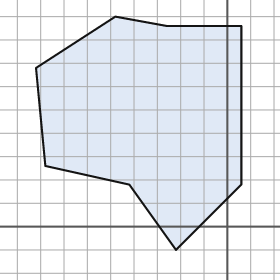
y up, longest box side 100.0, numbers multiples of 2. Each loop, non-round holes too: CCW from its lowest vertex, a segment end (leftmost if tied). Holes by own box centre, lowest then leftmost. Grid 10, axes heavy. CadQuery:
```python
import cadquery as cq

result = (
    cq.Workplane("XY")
    .moveTo(-22.0, -10.0)
    .lineTo(6.0, 18.0)
    .lineTo(6.0, 86.0)
    .lineTo(-26.0, 86.0)
    .lineTo(-48.0, 90.0)
    .lineTo(-82.0, 68.0)
    .lineTo(-78.0, 26.0)
    .lineTo(-42.0, 18.0)
    .close()
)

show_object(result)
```